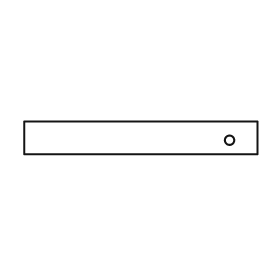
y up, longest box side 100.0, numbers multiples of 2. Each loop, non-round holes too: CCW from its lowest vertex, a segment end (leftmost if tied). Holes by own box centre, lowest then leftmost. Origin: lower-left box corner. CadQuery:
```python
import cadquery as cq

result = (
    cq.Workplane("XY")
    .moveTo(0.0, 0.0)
    .lineTo(100.0, 0.0)
    .lineTo(100.0, 14.0)
    .lineTo(0.0, 14.0)
    .close()
    .moveTo(88.0, 6.0)
    .circle(2.0)
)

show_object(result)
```